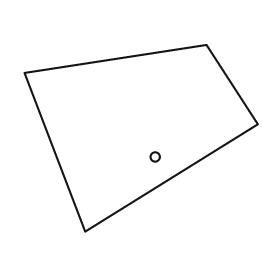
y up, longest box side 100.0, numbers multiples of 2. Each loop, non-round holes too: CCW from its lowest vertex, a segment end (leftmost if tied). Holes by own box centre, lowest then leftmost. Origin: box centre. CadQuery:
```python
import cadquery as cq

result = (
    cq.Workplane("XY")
    .moveTo(-24.0, -40.0)
    .lineTo(50.0, 6.0)
    .lineTo(28.0, 40.0)
    .lineTo(-50.0, 28.0)
    .close()
    .moveTo(6.0, -8.0)
    .circle(2.0)
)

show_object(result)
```